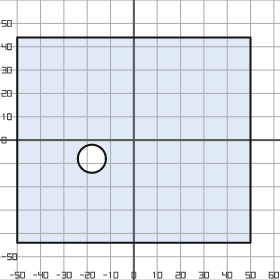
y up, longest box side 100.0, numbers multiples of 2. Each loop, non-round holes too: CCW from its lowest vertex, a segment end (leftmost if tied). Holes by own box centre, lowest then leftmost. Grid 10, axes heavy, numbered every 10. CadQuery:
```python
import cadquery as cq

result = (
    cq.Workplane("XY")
    .moveTo(-50.0, -44.0)
    .lineTo(50.0, -44.0)
    .lineTo(50.0, 44.0)
    .lineTo(-50.0, 44.0)
    .close()
    .moveTo(-18.0, -8.0)
    .circle(6.0)
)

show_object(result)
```